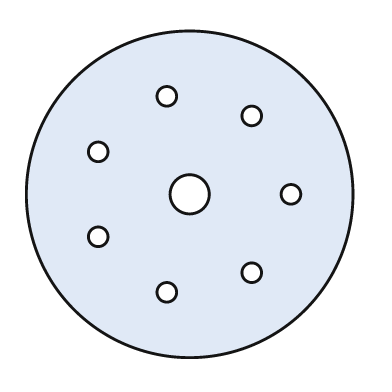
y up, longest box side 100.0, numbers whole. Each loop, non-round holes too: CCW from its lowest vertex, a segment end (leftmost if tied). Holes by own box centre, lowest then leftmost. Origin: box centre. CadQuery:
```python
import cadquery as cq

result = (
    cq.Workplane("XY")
    .moveTo(0.0, 0.0)
    .circle(50.0)
    .moveTo(-7.0, -30.0)
    .circle(3.0)
    .moveTo(19.0, -24.0)
    .circle(3.0)
    .moveTo(-28.0, -13.0)
    .circle(3.0)
    .moveTo(0.0, 0.0)
    .circle(6.0)
    .moveTo(31.0, 0.0)
    .circle(3.0)
    .moveTo(-28.0, 13.0)
    .circle(3.0)
    .moveTo(19.0, 24.0)
    .circle(3.0)
    .moveTo(-7.0, 30.0)
    .circle(3.0)
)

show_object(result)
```